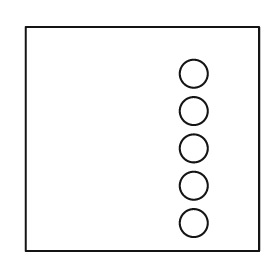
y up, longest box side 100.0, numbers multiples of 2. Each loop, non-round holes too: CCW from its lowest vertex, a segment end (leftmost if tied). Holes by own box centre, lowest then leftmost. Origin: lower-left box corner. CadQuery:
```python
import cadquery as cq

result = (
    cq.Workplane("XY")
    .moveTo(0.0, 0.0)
    .lineTo(100.0, 0.0)
    .lineTo(100.0, 96.0)
    .lineTo(0.0, 96.0)
    .close()
    .moveTo(72.0, 12.0)
    .circle(6.0)
    .moveTo(72.0, 28.0)
    .circle(6.0)
    .moveTo(72.0, 44.0)
    .circle(6.0)
    .moveTo(72.0, 60.0)
    .circle(6.0)
    .moveTo(72.0, 76.0)
    .circle(6.0)
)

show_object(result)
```